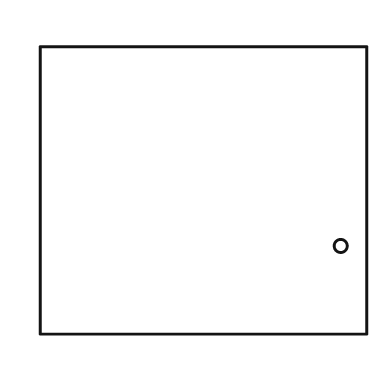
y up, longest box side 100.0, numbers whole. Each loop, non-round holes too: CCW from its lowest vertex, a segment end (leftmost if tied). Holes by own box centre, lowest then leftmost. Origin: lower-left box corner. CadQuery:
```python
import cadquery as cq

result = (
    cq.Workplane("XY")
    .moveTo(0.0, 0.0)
    .lineTo(100.0, 0.0)
    .lineTo(100.0, 88.0)
    .lineTo(0.0, 88.0)
    .close()
    .moveTo(92.0, 27.0)
    .circle(2.0)
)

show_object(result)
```